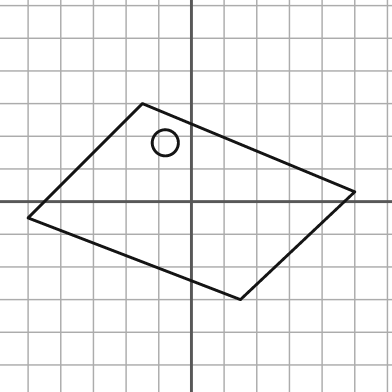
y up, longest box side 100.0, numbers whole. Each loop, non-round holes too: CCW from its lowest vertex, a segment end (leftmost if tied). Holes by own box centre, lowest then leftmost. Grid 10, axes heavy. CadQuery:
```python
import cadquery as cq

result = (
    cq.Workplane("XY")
    .moveTo(15.0, -30.0)
    .lineTo(50.0, 3.0)
    .lineTo(-15.0, 30.0)
    .lineTo(-50.0, -5.0)
    .close()
    .moveTo(-8.0, 18.0)
    .circle(4.0)
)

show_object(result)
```